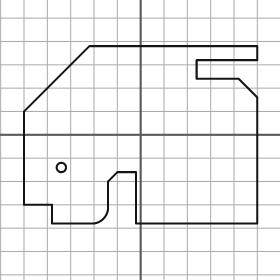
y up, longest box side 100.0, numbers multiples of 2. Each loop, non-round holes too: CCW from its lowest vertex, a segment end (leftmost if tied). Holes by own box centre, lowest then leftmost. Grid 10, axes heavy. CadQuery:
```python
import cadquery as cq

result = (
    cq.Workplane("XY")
    .moveTo(-38.0, -38.0)
    .lineTo(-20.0, -38.0)
    .threePointArc((-16.0, -36.0), (-14.0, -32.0))
    .lineTo(-14.0, -20.0)
    .lineTo(-10.0, -16.0)
    .lineTo(-2.0, -16.0)
    .lineTo(-2.0, -38.0)
    .lineTo(50.0, -38.0)
    .lineTo(50.0, 16.0)
    .lineTo(42.0, 24.0)
    .lineTo(24.0, 24.0)
    .lineTo(24.0, 32.0)
    .lineTo(50.0, 32.0)
    .lineTo(50.0, 38.0)
    .lineTo(-22.0, 38.0)
    .lineTo(-50.0, 10.0)
    .lineTo(-50.0, -30.0)
    .lineTo(-38.0, -30.0)
    .close()
    .moveTo(-34.0, -14.0)
    .circle(2.0)
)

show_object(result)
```